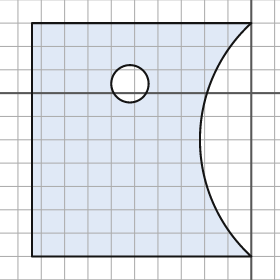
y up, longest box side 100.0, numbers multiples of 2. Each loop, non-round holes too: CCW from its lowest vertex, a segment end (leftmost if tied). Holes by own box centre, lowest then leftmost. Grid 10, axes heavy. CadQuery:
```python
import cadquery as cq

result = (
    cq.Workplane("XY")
    .moveTo(-94.0, -70.0)
    .lineTo(0.0, -70.0)
    .threePointArc((-22.0, -20.0), (0.0, 30.0))
    .lineTo(-94.0, 30.0)
    .close()
    .moveTo(-52.0, 4.0)
    .circle(8.0)
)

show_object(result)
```